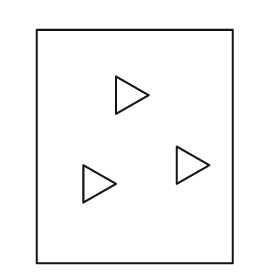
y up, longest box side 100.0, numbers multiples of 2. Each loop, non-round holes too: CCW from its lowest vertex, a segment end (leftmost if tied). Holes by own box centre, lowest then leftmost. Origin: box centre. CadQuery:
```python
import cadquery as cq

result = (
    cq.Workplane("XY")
    .moveTo(-42.0, -50.0)
    .lineTo(42.0, -50.0)
    .lineTo(42.0, 50.0)
    .lineTo(-42.0, 50.0)
    .close()
    .moveTo(-22.0, -24.0)
    .lineTo(-8.0, -16.0)
    .lineTo(-22.0, -8.0)
    .close()
    .moveTo(18.0, -16.0)
    .lineTo(32.0, -8.0)
    .lineTo(18.0, 0.0)
    .close()
    .moveTo(-8.0, 14.0)
    .lineTo(6.0, 22.0)
    .lineTo(-8.0, 30.0)
    .close()
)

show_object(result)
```